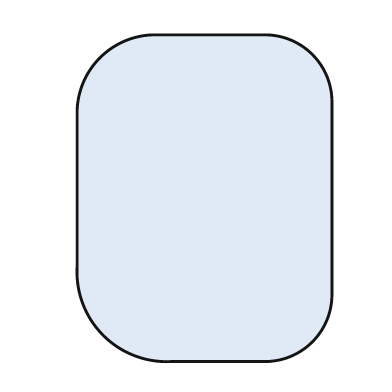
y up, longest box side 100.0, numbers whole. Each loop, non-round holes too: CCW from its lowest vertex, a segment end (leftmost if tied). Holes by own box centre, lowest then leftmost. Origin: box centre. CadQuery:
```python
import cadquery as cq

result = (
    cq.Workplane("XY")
    .moveTo(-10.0, -50.0)
    .lineTo(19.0, -50.0)
    .threePointArc((33.0, -44.0), (39.0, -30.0))
    .lineTo(39.0, 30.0)
    .threePointArc((33.0, 44.0), (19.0, 50.0))
    .lineTo(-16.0, 50.0)
    .threePointArc((-32.0, 43.0), (-39.0, 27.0))
    .lineTo(-39.0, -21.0)
    .threePointArc((-31.0, -42.0), (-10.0, -50.0))
    .close()
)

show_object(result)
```